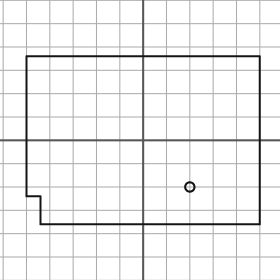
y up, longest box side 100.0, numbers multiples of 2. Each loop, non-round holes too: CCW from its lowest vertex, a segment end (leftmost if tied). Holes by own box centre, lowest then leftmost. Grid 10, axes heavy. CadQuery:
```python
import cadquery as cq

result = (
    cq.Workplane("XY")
    .moveTo(-44.0, -36.0)
    .lineTo(50.0, -36.0)
    .lineTo(50.0, 36.0)
    .lineTo(-50.0, 36.0)
    .lineTo(-50.0, -24.0)
    .lineTo(-44.0, -24.0)
    .close()
    .moveTo(20.0, -20.0)
    .circle(2.0)
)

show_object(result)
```